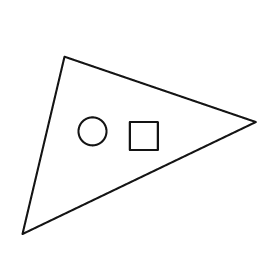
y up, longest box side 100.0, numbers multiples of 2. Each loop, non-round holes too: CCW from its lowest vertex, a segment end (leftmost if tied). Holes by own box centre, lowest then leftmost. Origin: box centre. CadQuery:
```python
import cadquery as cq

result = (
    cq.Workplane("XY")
    .moveTo(-50.0, -38.0)
    .lineTo(50.0, 10.0)
    .lineTo(-32.0, 38.0)
    .close()
    .moveTo(-4.0, -2.0)
    .lineTo(8.0, -2.0)
    .lineTo(8.0, 10.0)
    .lineTo(-4.0, 10.0)
    .close()
    .moveTo(-20.0, 6.0)
    .circle(6.0)
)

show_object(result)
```